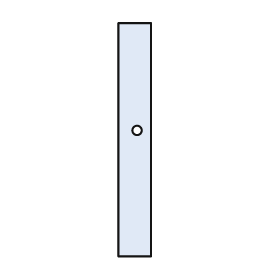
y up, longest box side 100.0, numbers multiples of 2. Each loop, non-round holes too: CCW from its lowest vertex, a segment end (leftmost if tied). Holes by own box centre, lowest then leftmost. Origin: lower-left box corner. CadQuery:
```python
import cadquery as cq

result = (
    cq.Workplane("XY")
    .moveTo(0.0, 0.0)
    .lineTo(14.0, 0.0)
    .lineTo(14.0, 100.0)
    .lineTo(0.0, 100.0)
    .close()
    .moveTo(8.0, 54.0)
    .circle(2.0)
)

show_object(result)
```